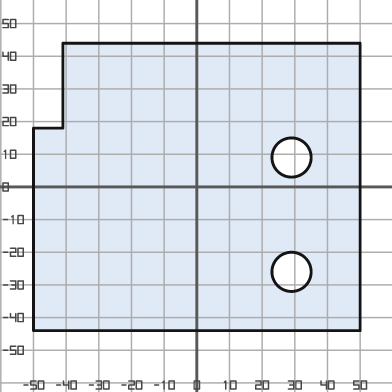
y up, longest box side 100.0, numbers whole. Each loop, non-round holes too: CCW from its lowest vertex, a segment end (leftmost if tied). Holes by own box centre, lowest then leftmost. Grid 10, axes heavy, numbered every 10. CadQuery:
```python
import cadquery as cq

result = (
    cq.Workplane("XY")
    .moveTo(-50.0, -44.0)
    .lineTo(50.0, -44.0)
    .lineTo(50.0, 44.0)
    .lineTo(-41.0, 44.0)
    .lineTo(-41.0, 18.0)
    .lineTo(-50.0, 18.0)
    .close()
    .moveTo(29.0, -26.0)
    .circle(6.0)
    .moveTo(29.0, 9.0)
    .circle(6.0)
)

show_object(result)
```